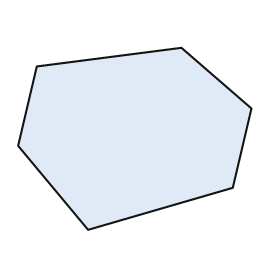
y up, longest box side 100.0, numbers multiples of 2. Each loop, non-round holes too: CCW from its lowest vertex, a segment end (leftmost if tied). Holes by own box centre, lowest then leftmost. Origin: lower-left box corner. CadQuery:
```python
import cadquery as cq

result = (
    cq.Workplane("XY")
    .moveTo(30.0, 0.0)
    .lineTo(92.0, 18.0)
    .lineTo(100.0, 52.0)
    .lineTo(70.0, 78.0)
    .lineTo(8.0, 70.0)
    .lineTo(0.0, 36.0)
    .close()
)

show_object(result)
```